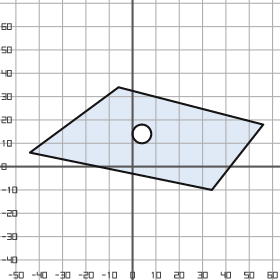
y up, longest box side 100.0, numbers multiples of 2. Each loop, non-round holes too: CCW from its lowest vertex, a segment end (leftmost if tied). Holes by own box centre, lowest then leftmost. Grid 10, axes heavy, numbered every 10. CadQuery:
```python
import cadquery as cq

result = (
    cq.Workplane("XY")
    .moveTo(34.0, -10.0)
    .lineTo(56.0, 18.0)
    .lineTo(-6.0, 34.0)
    .lineTo(-44.0, 6.0)
    .close()
    .moveTo(4.0, 14.0)
    .circle(4.0)
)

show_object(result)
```